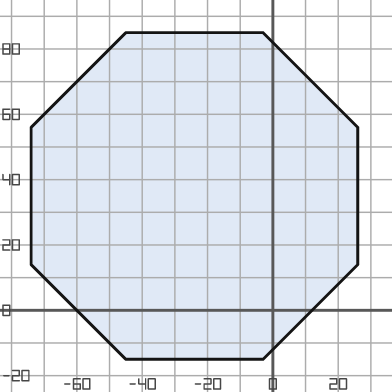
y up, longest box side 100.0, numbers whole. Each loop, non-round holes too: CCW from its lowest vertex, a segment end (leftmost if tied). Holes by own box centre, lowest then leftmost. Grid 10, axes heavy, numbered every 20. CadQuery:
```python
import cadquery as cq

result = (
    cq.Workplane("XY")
    .moveTo(-45.0, -15.0)
    .lineTo(-3.0, -15.0)
    .lineTo(26.0, 14.0)
    .lineTo(26.0, 56.0)
    .lineTo(-3.0, 85.0)
    .lineTo(-45.0, 85.0)
    .lineTo(-74.0, 56.0)
    .lineTo(-74.0, 14.0)
    .close()
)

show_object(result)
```